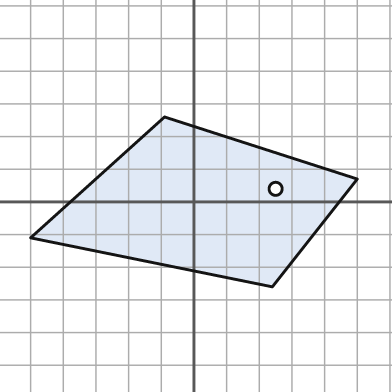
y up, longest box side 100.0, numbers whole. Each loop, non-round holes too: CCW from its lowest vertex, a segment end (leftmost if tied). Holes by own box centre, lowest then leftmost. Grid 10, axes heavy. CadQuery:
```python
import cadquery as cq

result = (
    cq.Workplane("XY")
    .moveTo(24.0, -26.0)
    .lineTo(50.0, 7.0)
    .lineTo(-9.0, 26.0)
    .lineTo(-50.0, -11.0)
    .close()
    .moveTo(25.0, 4.0)
    .circle(2.0)
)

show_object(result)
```